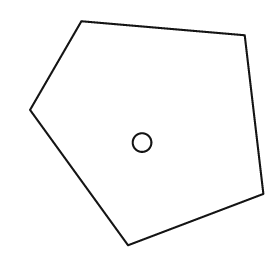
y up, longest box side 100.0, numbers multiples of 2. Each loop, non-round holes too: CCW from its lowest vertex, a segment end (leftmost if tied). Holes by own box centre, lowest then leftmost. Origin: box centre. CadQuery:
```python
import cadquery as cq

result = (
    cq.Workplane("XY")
    .moveTo(-8.0, -48.0)
    .lineTo(50.0, -26.0)
    .lineTo(42.0, 42.0)
    .lineTo(-28.0, 48.0)
    .lineTo(-50.0, 10.0)
    .close()
    .moveTo(-2.0, -4.0)
    .circle(4.0)
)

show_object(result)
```